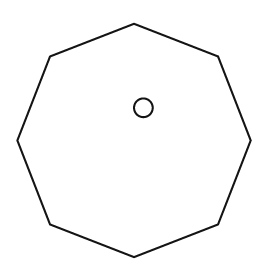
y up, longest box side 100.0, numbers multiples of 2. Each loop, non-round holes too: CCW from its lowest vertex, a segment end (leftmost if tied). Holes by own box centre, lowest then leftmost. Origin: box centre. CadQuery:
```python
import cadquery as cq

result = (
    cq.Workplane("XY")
    .moveTo(0.0, -50.0)
    .lineTo(36.0, -36.0)
    .lineTo(50.0, 0.0)
    .lineTo(36.0, 36.0)
    .lineTo(0.0, 50.0)
    .lineTo(-36.0, 36.0)
    .lineTo(-50.0, 0.0)
    .lineTo(-36.0, -36.0)
    .close()
    .moveTo(4.0, 14.0)
    .circle(4.0)
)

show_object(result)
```